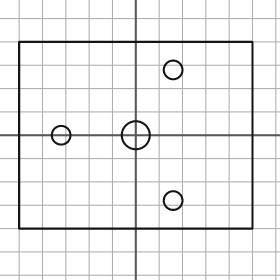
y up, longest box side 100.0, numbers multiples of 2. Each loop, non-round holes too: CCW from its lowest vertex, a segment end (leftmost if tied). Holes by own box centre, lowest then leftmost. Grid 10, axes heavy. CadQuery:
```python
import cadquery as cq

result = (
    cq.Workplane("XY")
    .moveTo(-50.0, -40.0)
    .lineTo(50.0, -40.0)
    .lineTo(50.0, 40.0)
    .lineTo(-50.0, 40.0)
    .close()
    .moveTo(16.0, -28.0)
    .circle(4.0)
    .moveTo(-32.0, 0.0)
    .circle(4.0)
    .moveTo(0.0, 0.0)
    .circle(6.0)
    .moveTo(16.0, 28.0)
    .circle(4.0)
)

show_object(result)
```